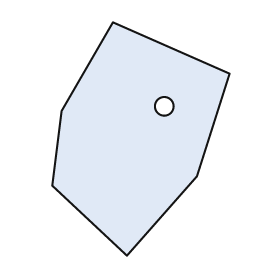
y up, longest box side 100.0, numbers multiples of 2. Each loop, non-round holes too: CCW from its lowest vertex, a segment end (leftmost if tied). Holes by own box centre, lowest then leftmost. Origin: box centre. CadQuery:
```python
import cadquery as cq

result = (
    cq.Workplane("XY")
    .moveTo(-6.0, -50.0)
    .lineTo(24.0, -16.0)
    .lineTo(38.0, 28.0)
    .lineTo(-12.0, 50.0)
    .lineTo(-34.0, 12.0)
    .lineTo(-38.0, -20.0)
    .close()
    .moveTo(10.0, 14.0)
    .circle(4.0)
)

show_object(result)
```